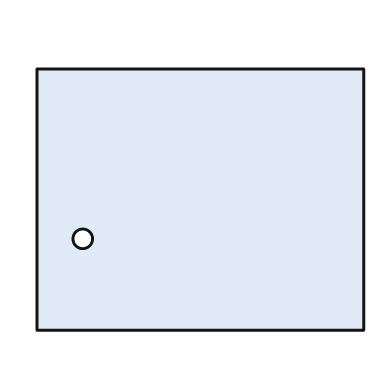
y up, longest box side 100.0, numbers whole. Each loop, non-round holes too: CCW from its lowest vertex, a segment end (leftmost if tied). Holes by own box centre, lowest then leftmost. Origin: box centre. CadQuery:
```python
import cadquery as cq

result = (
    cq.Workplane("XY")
    .moveTo(-50.0, -40.0)
    .lineTo(50.0, -40.0)
    .lineTo(50.0, 40.0)
    .lineTo(-50.0, 40.0)
    .close()
    .moveTo(-36.0, -12.0)
    .circle(3.0)
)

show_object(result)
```